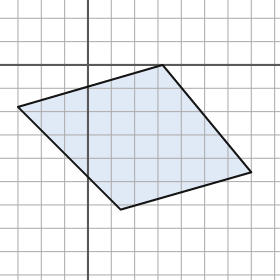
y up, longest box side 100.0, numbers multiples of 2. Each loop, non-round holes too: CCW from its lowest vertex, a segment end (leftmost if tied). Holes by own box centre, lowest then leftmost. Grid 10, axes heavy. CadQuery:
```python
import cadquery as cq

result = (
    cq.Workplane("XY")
    .moveTo(14.0, -62.0)
    .lineTo(70.0, -46.0)
    .lineTo(32.0, 0.0)
    .lineTo(-30.0, -18.0)
    .close()
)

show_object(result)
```